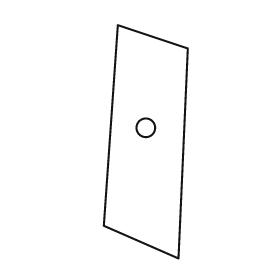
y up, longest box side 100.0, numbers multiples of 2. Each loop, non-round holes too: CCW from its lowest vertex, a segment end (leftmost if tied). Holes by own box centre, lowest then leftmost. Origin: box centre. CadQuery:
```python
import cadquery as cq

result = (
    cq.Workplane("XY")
    .moveTo(14.0, -50.0)
    .lineTo(18.0, 40.0)
    .lineTo(-12.0, 50.0)
    .lineTo(-18.0, -36.0)
    .close()
    .moveTo(0.0, 6.0)
    .circle(4.0)
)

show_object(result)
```